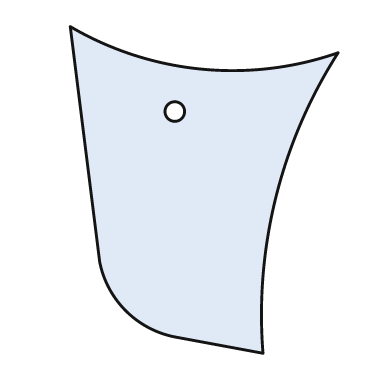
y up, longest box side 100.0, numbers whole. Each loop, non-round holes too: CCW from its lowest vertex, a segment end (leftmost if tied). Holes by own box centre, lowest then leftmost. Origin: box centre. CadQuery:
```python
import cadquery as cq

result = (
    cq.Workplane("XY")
    .moveTo(18.0, -50.0)
    .threePointArc((22.0, -2.0), (41.0, 42.0))
    .threePointArc((-1.0, 37.0), (-41.0, 50.0))
    .lineTo(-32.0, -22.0)
    .threePointArc((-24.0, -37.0), (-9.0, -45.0))
    .close()
    .moveTo(-9.0, 24.0)
    .circle(3.0)
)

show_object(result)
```